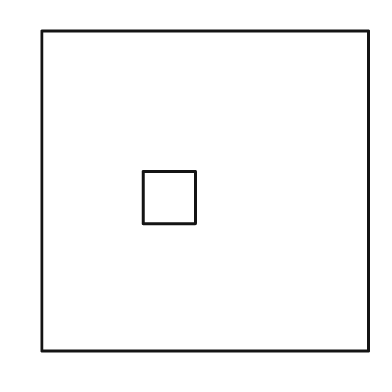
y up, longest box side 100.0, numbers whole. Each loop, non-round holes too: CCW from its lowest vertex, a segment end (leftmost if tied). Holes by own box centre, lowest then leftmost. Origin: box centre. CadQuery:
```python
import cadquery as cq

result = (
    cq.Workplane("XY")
    .moveTo(-50.0, -49.0)
    .lineTo(50.0, -49.0)
    .lineTo(50.0, 49.0)
    .lineTo(-50.0, 49.0)
    .close()
    .moveTo(-19.0, -10.0)
    .lineTo(-3.0, -10.0)
    .lineTo(-3.0, 6.0)
    .lineTo(-19.0, 6.0)
    .close()
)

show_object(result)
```